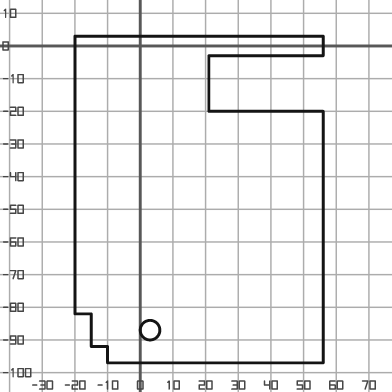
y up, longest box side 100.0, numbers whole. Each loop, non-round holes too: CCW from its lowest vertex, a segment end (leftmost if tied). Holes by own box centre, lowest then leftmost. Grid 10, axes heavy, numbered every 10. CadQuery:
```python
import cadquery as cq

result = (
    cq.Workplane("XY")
    .moveTo(-10.0, -97.0)
    .lineTo(56.0, -97.0)
    .lineTo(56.0, -20.0)
    .lineTo(21.0, -20.0)
    .lineTo(21.0, -3.0)
    .lineTo(56.0, -3.0)
    .lineTo(56.0, 3.0)
    .lineTo(-20.0, 3.0)
    .lineTo(-20.0, -82.0)
    .lineTo(-15.0, -82.0)
    .lineTo(-15.0, -92.0)
    .lineTo(-10.0, -92.0)
    .close()
    .moveTo(3.0, -87.0)
    .circle(3.0)
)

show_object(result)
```